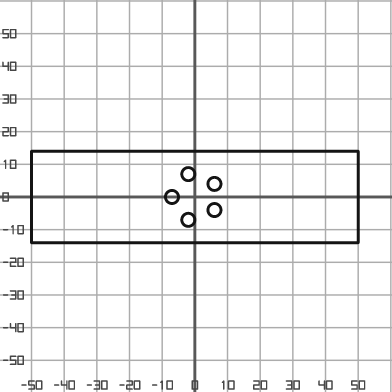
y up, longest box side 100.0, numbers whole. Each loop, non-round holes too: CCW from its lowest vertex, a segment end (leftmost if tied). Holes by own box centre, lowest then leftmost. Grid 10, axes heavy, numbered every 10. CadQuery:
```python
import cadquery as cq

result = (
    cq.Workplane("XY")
    .moveTo(-50.0, -14.0)
    .lineTo(50.0, -14.0)
    .lineTo(50.0, 14.0)
    .lineTo(-50.0, 14.0)
    .close()
    .moveTo(-2.0, -7.0)
    .circle(2.0)
    .moveTo(6.0, -4.0)
    .circle(2.0)
    .moveTo(-7.0, 0.0)
    .circle(2.0)
    .moveTo(6.0, 4.0)
    .circle(2.0)
    .moveTo(-2.0, 7.0)
    .circle(2.0)
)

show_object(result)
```